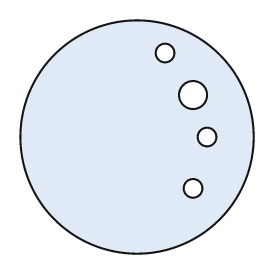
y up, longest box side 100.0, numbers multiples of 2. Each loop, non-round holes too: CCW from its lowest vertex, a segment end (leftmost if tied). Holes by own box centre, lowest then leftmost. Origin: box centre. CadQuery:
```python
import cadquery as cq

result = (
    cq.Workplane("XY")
    .moveTo(0.0, 0.0)
    .circle(50.0)
    .moveTo(24.0, -22.0)
    .circle(4.0)
    .moveTo(30.0, 0.0)
    .circle(4.0)
    .moveTo(24.0, 18.0)
    .circle(6.0)
    .moveTo(12.0, 36.0)
    .circle(4.0)
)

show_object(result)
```